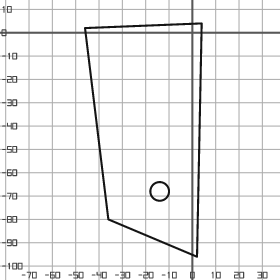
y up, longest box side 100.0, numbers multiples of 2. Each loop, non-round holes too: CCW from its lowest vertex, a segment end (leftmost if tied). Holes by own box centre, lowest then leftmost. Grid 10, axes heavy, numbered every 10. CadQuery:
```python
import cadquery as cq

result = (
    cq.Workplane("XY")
    .moveTo(2.0, -96.0)
    .lineTo(4.0, 4.0)
    .lineTo(-46.0, 2.0)
    .lineTo(-36.0, -80.0)
    .close()
    .moveTo(-14.0, -68.0)
    .circle(4.0)
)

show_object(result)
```